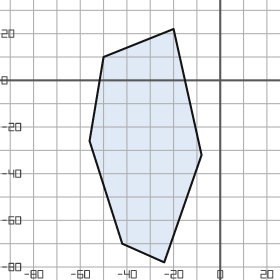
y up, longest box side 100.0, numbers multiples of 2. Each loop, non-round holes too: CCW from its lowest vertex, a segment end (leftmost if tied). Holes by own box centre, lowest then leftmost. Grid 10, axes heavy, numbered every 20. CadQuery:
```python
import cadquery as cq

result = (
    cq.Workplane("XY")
    .moveTo(-24.0, -78.0)
    .lineTo(-8.0, -32.0)
    .lineTo(-20.0, 22.0)
    .lineTo(-50.0, 10.0)
    .lineTo(-56.0, -26.0)
    .lineTo(-42.0, -70.0)
    .close()
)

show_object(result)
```